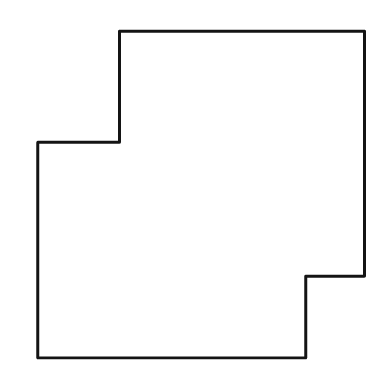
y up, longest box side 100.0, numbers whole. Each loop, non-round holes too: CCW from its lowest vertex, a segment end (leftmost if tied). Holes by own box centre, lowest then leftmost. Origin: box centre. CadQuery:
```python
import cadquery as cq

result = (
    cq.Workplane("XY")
    .moveTo(-50.0, -50.0)
    .lineTo(32.0, -50.0)
    .lineTo(32.0, -25.0)
    .lineTo(50.0, -25.0)
    .lineTo(50.0, 50.0)
    .lineTo(-25.0, 50.0)
    .lineTo(-25.0, 16.0)
    .lineTo(-50.0, 16.0)
    .close()
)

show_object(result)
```